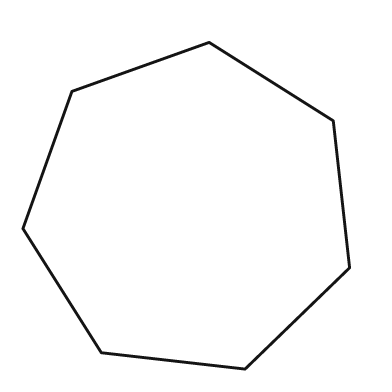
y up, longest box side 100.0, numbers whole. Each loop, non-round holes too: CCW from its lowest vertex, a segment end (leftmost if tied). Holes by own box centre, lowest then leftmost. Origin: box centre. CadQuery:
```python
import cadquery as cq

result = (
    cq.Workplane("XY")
    .moveTo(18.0, -50.0)
    .lineTo(50.0, -19.0)
    .lineTo(45.0, 26.0)
    .lineTo(7.0, 50.0)
    .lineTo(-35.0, 35.0)
    .lineTo(-50.0, -7.0)
    .lineTo(-26.0, -45.0)
    .close()
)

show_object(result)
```